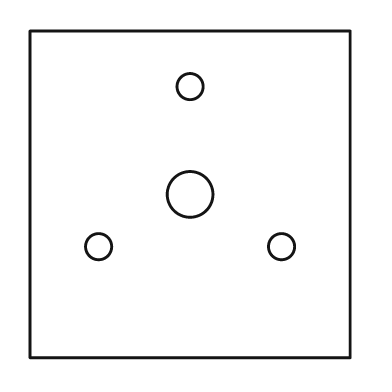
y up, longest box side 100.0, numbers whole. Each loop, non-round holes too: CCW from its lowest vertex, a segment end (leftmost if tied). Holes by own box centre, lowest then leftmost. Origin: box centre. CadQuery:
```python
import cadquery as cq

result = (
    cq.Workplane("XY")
    .moveTo(-49.0, -50.0)
    .lineTo(49.0, -50.0)
    .lineTo(49.0, 50.0)
    .lineTo(-49.0, 50.0)
    .close()
    .moveTo(-28.0, -16.0)
    .circle(4.0)
    .moveTo(28.0, -16.0)
    .circle(4.0)
    .moveTo(0.0, 0.0)
    .circle(7.0)
    .moveTo(0.0, 33.0)
    .circle(4.0)
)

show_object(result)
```